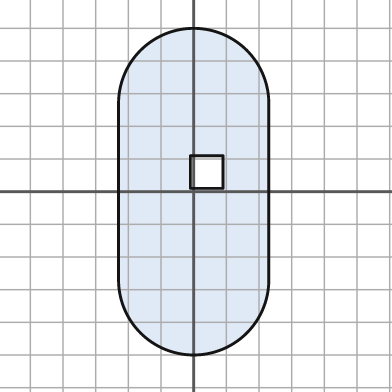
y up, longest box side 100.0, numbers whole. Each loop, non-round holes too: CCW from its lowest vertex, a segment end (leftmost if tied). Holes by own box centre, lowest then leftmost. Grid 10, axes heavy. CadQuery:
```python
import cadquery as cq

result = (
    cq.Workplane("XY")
    .moveTo(-23.0, -27.0)
    .threePointArc((0.0, -50.0), (23.0, -27.0))
    .lineTo(23.0, 27.0)
    .threePointArc((0.0, 50.0), (-23.0, 27.0))
    .close()
    .moveTo(-1.0, 1.0)
    .lineTo(9.0, 1.0)
    .lineTo(9.0, 11.0)
    .lineTo(-1.0, 11.0)
    .close()
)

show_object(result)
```